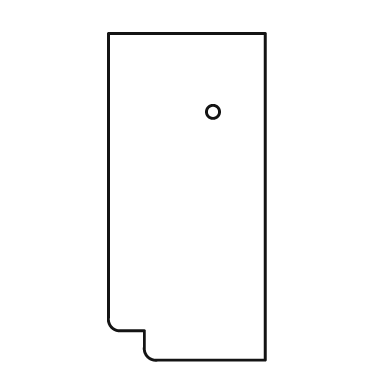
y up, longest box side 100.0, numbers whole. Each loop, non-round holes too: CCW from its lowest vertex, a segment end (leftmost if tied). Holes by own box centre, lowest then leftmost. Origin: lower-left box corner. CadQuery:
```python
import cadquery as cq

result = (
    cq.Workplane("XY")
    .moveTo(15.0, 0.0)
    .lineTo(48.0, 0.0)
    .lineTo(48.0, 100.0)
    .lineTo(0.0, 100.0)
    .lineTo(0.0, 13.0)
    .threePointArc((1.0, 10.0), (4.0, 9.0))
    .lineTo(11.0, 9.0)
    .lineTo(11.0, 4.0)
    .threePointArc((12.0, 1.0), (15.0, 0.0))
    .close()
    .moveTo(32.0, 76.0)
    .circle(2.0)
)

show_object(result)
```